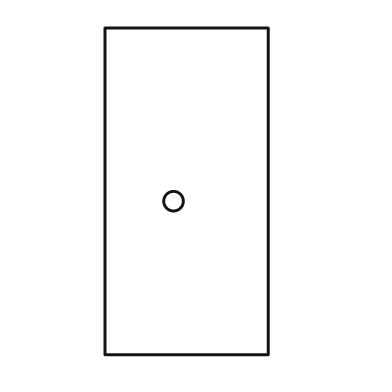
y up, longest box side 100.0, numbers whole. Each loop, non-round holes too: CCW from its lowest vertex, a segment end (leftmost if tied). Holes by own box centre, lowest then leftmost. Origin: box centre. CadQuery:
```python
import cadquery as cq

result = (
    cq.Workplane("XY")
    .moveTo(-25.0, -50.0)
    .lineTo(25.0, -50.0)
    .lineTo(25.0, 50.0)
    .lineTo(-25.0, 50.0)
    .close()
    .moveTo(-4.0, -3.0)
    .circle(3.0)
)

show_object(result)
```